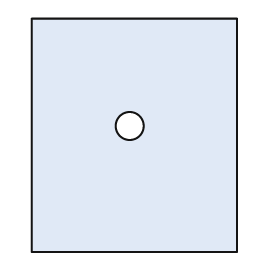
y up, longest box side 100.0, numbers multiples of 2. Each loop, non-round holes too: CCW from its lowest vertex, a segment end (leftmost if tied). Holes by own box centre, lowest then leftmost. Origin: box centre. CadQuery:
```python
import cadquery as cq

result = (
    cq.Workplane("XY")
    .moveTo(-44.0, -50.0)
    .lineTo(44.0, -50.0)
    .lineTo(44.0, 50.0)
    .lineTo(-44.0, 50.0)
    .close()
    .moveTo(-2.0, 4.0)
    .circle(6.0)
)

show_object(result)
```